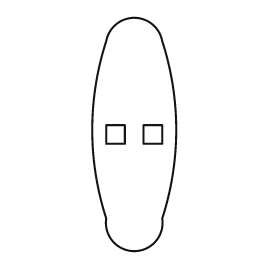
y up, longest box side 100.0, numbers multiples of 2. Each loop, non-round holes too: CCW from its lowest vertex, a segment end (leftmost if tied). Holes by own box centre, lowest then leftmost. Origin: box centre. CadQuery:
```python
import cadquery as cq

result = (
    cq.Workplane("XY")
    .moveTo(-12.0, -36.0)
    .threePointArc((0.0, -50.0), (12.0, -36.0))
    .threePointArc((18.0, 2.0), (12.0, 40.0))
    .threePointArc((0.0, 50.0), (-12.0, 40.0))
    .threePointArc((-18.0, 2.0), (-12.0, -36.0))
    .close()
    .moveTo(-12.0, -4.0)
    .lineTo(-4.0, -4.0)
    .lineTo(-4.0, 4.0)
    .lineTo(-12.0, 4.0)
    .close()
    .moveTo(4.0, -4.0)
    .lineTo(12.0, -4.0)
    .lineTo(12.0, 4.0)
    .lineTo(4.0, 4.0)
    .close()
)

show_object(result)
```